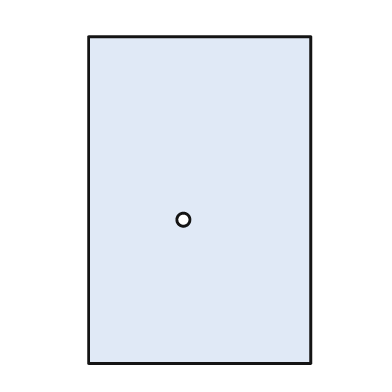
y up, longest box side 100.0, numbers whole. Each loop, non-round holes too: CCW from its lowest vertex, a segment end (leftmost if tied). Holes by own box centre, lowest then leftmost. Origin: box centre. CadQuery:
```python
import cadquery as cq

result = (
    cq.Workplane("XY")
    .moveTo(-34.0, -50.0)
    .lineTo(34.0, -50.0)
    .lineTo(34.0, 50.0)
    .lineTo(-34.0, 50.0)
    .close()
    .moveTo(-5.0, -6.0)
    .circle(2.0)
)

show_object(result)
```